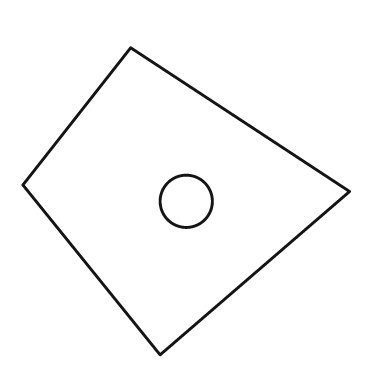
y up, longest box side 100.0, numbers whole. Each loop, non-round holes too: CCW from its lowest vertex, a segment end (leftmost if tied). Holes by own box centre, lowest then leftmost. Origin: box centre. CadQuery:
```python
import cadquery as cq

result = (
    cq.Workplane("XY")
    .moveTo(-8.0, -47.0)
    .lineTo(50.0, 3.0)
    .lineTo(-17.0, 47.0)
    .lineTo(-50.0, 5.0)
    .close()
    .moveTo(0.0, 0.0)
    .circle(8.0)
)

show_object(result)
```